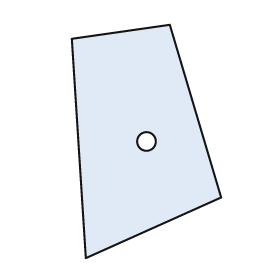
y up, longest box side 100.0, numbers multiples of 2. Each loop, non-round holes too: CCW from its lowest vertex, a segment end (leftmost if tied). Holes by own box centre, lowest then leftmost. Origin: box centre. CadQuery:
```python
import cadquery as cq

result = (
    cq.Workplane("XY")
    .moveTo(-26.0, -50.0)
    .lineTo(32.0, -24.0)
    .lineTo(10.0, 50.0)
    .lineTo(-32.0, 44.0)
    .close()
    .moveTo(0.0, 0.0)
    .circle(4.0)
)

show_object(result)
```